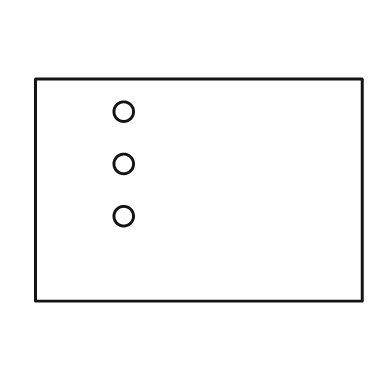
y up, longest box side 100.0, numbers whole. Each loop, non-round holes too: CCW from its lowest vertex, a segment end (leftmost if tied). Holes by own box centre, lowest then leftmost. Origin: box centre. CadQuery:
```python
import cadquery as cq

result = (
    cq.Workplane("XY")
    .moveTo(-50.0, -34.0)
    .lineTo(50.0, -34.0)
    .lineTo(50.0, 34.0)
    .lineTo(-50.0, 34.0)
    .close()
    .moveTo(-23.0, -8.0)
    .circle(3.0)
    .moveTo(-23.0, 8.0)
    .circle(3.0)
    .moveTo(-23.0, 24.0)
    .circle(3.0)
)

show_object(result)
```